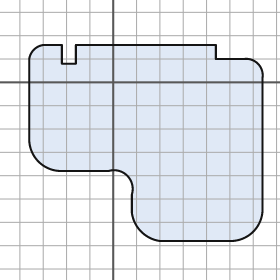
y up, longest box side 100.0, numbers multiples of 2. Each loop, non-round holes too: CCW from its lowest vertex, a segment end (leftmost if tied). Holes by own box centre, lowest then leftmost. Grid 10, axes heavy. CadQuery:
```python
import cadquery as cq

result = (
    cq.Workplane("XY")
    .moveTo(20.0, -68.0)
    .lineTo(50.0, -68.0)
    .threePointArc((60.0, -64.0), (64.0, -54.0))
    .lineTo(64.0, 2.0)
    .threePointArc((62.0, 8.0), (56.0, 10.0))
    .lineTo(44.0, 10.0)
    .lineTo(44.0, 16.0)
    .lineTo(-16.0, 16.0)
    .lineTo(-16.0, 8.0)
    .lineTo(-22.0, 8.0)
    .lineTo(-22.0, 16.0)
    .lineTo(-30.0, 16.0)
    .threePointArc((-34.0, 14.0), (-36.0, 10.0))
    .lineTo(-36.0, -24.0)
    .threePointArc((-32.0, -34.0), (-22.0, -38.0))
    .lineTo(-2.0, -38.0)
    .threePointArc((6.0, -40.0), (8.0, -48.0))
    .lineTo(8.0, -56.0)
    .threePointArc((12.0, -64.0), (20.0, -68.0))
    .close()
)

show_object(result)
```